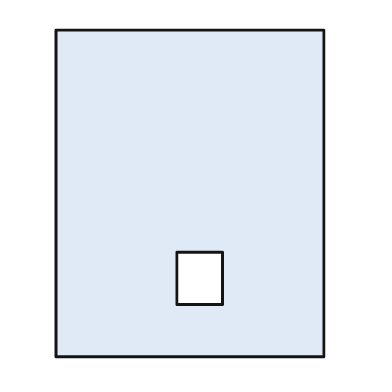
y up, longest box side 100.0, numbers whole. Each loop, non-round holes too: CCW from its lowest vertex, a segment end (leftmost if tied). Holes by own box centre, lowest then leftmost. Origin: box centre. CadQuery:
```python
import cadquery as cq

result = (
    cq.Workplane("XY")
    .moveTo(-41.0, -50.0)
    .lineTo(41.0, -50.0)
    .lineTo(41.0, 50.0)
    .lineTo(-41.0, 50.0)
    .close()
    .moveTo(-4.0, -34.0)
    .lineTo(10.0, -34.0)
    .lineTo(10.0, -18.0)
    .lineTo(-4.0, -18.0)
    .close()
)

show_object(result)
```